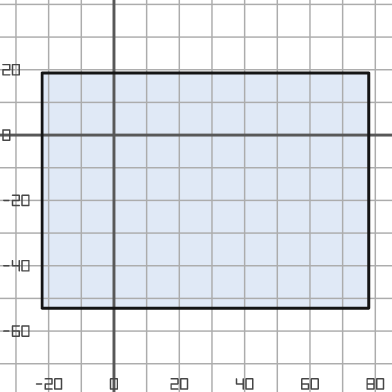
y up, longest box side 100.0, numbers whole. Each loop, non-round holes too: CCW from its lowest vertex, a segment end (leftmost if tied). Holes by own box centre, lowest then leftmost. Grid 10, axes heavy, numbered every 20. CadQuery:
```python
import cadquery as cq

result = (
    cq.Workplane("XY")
    .moveTo(-22.0, -53.0)
    .lineTo(78.0, -53.0)
    .lineTo(78.0, 19.0)
    .lineTo(-22.0, 19.0)
    .close()
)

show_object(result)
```